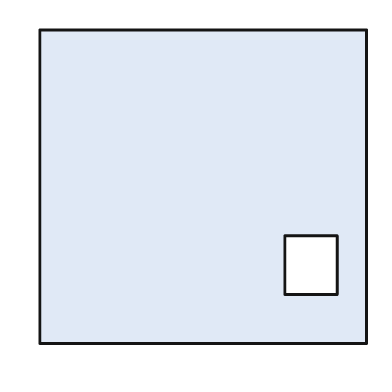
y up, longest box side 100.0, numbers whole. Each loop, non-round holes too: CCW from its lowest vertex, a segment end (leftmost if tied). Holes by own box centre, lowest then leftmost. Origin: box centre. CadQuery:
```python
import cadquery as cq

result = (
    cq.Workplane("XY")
    .moveTo(-50.0, -48.0)
    .lineTo(50.0, -48.0)
    .lineTo(50.0, 48.0)
    .lineTo(-50.0, 48.0)
    .close()
    .moveTo(25.0, -33.0)
    .lineTo(41.0, -33.0)
    .lineTo(41.0, -15.0)
    .lineTo(25.0, -15.0)
    .close()
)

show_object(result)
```